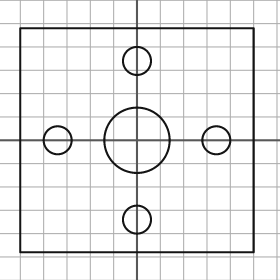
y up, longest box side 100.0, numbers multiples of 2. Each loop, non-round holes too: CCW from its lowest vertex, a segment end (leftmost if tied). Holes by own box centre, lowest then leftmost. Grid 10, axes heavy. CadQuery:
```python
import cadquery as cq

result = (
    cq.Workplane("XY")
    .moveTo(-50.0, -48.0)
    .lineTo(50.0, -48.0)
    .lineTo(50.0, 48.0)
    .lineTo(-50.0, 48.0)
    .close()
    .moveTo(0.0, -34.0)
    .circle(6.0)
    .moveTo(-34.0, 0.0)
    .circle(6.0)
    .moveTo(0.0, 0.0)
    .circle(14.0)
    .moveTo(34.0, 0.0)
    .circle(6.0)
    .moveTo(0.0, 34.0)
    .circle(6.0)
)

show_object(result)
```